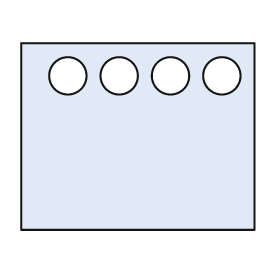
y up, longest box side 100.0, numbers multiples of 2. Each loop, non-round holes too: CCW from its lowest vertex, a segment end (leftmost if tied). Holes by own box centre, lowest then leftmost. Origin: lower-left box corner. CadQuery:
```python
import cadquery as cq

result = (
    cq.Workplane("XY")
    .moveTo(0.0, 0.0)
    .lineTo(100.0, 0.0)
    .lineTo(100.0, 80.0)
    .lineTo(0.0, 80.0)
    .close()
    .moveTo(20.0, 66.0)
    .circle(8.0)
    .moveTo(42.0, 66.0)
    .circle(8.0)
    .moveTo(64.0, 66.0)
    .circle(8.0)
    .moveTo(86.0, 66.0)
    .circle(8.0)
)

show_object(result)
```